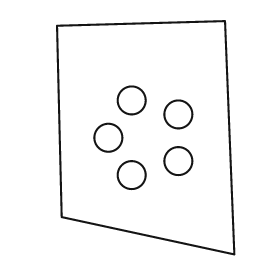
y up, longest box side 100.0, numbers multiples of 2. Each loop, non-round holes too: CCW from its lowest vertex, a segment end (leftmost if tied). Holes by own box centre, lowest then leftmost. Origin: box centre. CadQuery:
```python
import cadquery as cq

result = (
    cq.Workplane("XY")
    .moveTo(38.0, -50.0)
    .lineTo(34.0, 50.0)
    .lineTo(-38.0, 48.0)
    .lineTo(-36.0, -34.0)
    .close()
    .moveTo(-6.0, -16.0)
    .circle(6.0)
    .moveTo(14.0, -10.0)
    .circle(6.0)
    .moveTo(-16.0, 0.0)
    .circle(6.0)
    .moveTo(14.0, 10.0)
    .circle(6.0)
    .moveTo(-6.0, 16.0)
    .circle(6.0)
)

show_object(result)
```